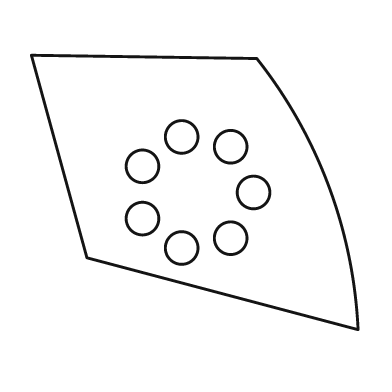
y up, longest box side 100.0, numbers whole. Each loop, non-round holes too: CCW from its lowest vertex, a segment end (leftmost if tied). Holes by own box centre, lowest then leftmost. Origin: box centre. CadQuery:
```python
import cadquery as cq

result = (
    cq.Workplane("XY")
    .moveTo(50.0, -42.0)
    .threePointArc((41.0, 2.0), (19.0, 41.0))
    .lineTo(-50.0, 42.0)
    .lineTo(-33.0, -20.0)
    .close()
    .moveTo(-4.0, -17.0)
    .circle(5.0)
    .moveTo(11.0, -14.0)
    .circle(5.0)
    .moveTo(-16.0, -8.0)
    .circle(5.0)
    .moveTo(18.0, 0.0)
    .circle(5.0)
    .moveTo(-16.0, 8.0)
    .circle(5.0)
    .moveTo(11.0, 14.0)
    .circle(5.0)
    .moveTo(-4.0, 17.0)
    .circle(5.0)
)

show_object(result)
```